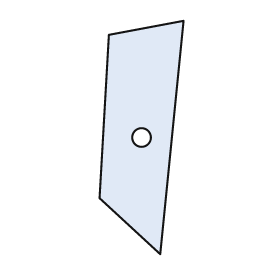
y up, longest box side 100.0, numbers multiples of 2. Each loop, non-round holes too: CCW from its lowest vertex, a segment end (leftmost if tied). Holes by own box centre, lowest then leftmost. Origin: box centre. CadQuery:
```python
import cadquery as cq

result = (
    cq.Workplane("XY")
    .moveTo(8.0, -50.0)
    .lineTo(18.0, 50.0)
    .lineTo(-14.0, 44.0)
    .lineTo(-18.0, -26.0)
    .close()
    .moveTo(0.0, 0.0)
    .circle(4.0)
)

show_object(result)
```